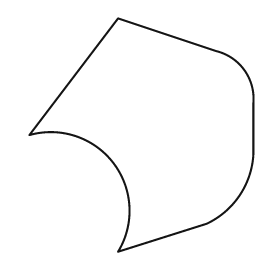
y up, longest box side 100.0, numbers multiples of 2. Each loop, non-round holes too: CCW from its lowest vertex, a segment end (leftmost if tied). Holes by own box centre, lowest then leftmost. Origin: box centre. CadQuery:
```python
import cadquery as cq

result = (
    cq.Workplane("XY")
    .moveTo(-10.0, -50.0)
    .lineTo(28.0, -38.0)
    .threePointArc((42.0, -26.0), (48.0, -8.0))
    .lineTo(48.0, 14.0)
    .threePointArc((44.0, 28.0), (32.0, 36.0))
    .lineTo(-10.0, 50.0)
    .lineTo(-48.0, 0.0)
    .threePointArc((-12.0, -12.0), (-10.0, -50.0))
    .close()
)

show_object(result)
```